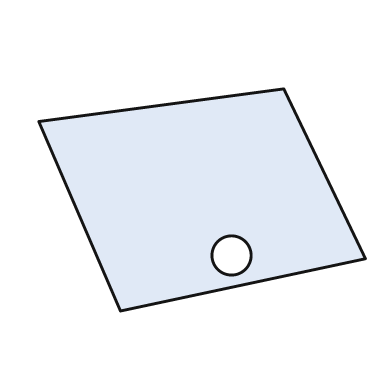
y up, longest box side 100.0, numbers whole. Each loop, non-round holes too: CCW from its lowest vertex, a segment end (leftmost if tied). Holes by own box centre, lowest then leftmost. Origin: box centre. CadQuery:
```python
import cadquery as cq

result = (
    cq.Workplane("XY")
    .moveTo(-25.0, -34.0)
    .lineTo(50.0, -18.0)
    .lineTo(25.0, 34.0)
    .lineTo(-50.0, 24.0)
    .close()
    .moveTo(9.0, -17.0)
    .circle(6.0)
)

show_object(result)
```